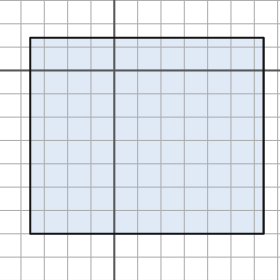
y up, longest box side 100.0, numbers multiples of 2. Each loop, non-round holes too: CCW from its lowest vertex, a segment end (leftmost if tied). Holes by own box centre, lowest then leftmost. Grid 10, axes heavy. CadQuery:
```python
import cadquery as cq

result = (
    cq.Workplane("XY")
    .moveTo(-36.0, -70.0)
    .lineTo(64.0, -70.0)
    .lineTo(64.0, 14.0)
    .lineTo(-36.0, 14.0)
    .close()
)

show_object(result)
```